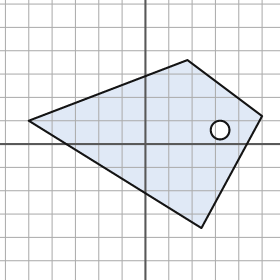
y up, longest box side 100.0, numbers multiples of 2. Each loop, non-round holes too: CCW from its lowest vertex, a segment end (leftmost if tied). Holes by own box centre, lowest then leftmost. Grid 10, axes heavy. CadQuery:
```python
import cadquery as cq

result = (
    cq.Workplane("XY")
    .moveTo(24.0, -36.0)
    .lineTo(50.0, 12.0)
    .lineTo(18.0, 36.0)
    .lineTo(-50.0, 10.0)
    .close()
    .moveTo(32.0, 6.0)
    .circle(4.0)
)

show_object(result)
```